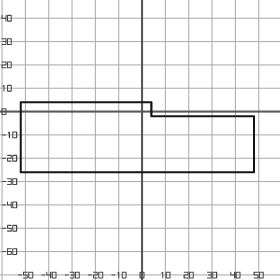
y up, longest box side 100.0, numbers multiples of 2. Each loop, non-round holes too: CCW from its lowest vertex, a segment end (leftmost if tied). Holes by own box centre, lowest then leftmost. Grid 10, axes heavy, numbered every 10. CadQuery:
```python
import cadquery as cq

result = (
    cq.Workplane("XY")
    .moveTo(-52.0, -26.0)
    .lineTo(48.0, -26.0)
    .lineTo(48.0, -2.0)
    .lineTo(4.0, -2.0)
    .lineTo(4.0, 4.0)
    .lineTo(-52.0, 4.0)
    .close()
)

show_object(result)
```